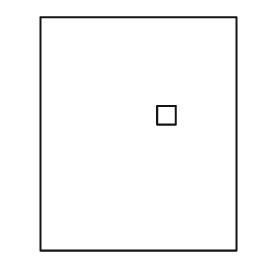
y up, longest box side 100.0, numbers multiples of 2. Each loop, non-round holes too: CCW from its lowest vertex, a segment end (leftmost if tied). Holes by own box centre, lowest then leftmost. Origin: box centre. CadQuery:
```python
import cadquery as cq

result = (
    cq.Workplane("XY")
    .moveTo(-42.0, -50.0)
    .lineTo(42.0, -50.0)
    .lineTo(42.0, 50.0)
    .lineTo(-42.0, 50.0)
    .close()
    .moveTo(8.0, 4.0)
    .lineTo(16.0, 4.0)
    .lineTo(16.0, 12.0)
    .lineTo(8.0, 12.0)
    .close()
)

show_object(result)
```